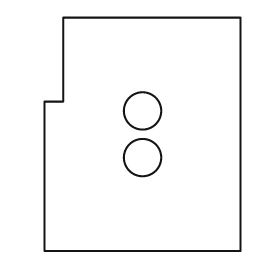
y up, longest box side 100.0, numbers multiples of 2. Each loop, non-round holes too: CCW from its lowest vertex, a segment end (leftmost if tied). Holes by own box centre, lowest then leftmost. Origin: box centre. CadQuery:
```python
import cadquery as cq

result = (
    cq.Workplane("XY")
    .moveTo(-42.0, -50.0)
    .lineTo(42.0, -50.0)
    .lineTo(42.0, 50.0)
    .lineTo(-34.0, 50.0)
    .lineTo(-34.0, 14.0)
    .lineTo(-42.0, 14.0)
    .close()
    .moveTo(0.0, -10.0)
    .circle(8.0)
    .moveTo(0.0, 10.0)
    .circle(8.0)
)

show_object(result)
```